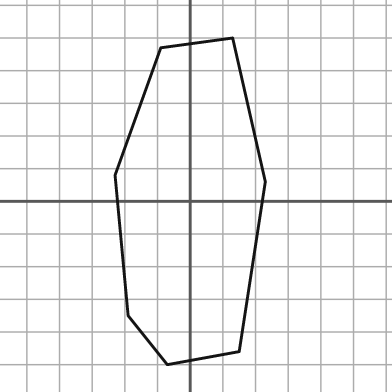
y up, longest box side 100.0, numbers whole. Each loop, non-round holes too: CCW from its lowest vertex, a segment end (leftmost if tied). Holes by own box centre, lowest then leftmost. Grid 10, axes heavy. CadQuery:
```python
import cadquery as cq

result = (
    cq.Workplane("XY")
    .moveTo(-7.0, -50.0)
    .lineTo(15.0, -46.0)
    .lineTo(23.0, 6.0)
    .lineTo(13.0, 50.0)
    .lineTo(-9.0, 47.0)
    .lineTo(-23.0, 8.0)
    .lineTo(-19.0, -35.0)
    .close()
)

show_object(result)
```